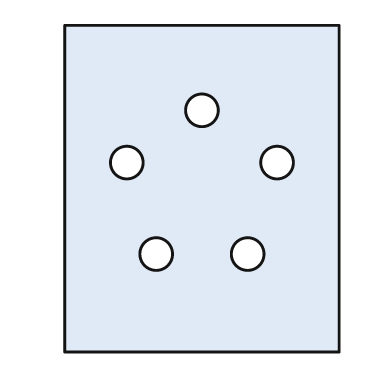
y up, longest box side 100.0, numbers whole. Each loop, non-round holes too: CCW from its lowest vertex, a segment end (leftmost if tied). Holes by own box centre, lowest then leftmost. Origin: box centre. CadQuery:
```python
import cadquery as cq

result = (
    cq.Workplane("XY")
    .moveTo(-42.0, -50.0)
    .lineTo(42.0, -50.0)
    .lineTo(42.0, 50.0)
    .lineTo(-42.0, 50.0)
    .close()
    .moveTo(-14.0, -20.0)
    .circle(5.0)
    .moveTo(14.0, -20.0)
    .circle(5.0)
    .moveTo(-23.0, 8.0)
    .circle(5.0)
    .moveTo(23.0, 8.0)
    .circle(5.0)
    .moveTo(0.0, 24.0)
    .circle(5.0)
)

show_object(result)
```